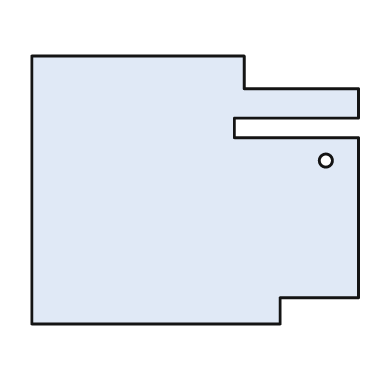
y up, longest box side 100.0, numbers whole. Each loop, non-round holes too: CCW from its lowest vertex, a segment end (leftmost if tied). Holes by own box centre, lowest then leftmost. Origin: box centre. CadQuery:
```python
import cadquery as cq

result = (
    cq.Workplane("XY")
    .moveTo(-50.0, -41.0)
    .lineTo(26.0, -41.0)
    .lineTo(26.0, -33.0)
    .lineTo(50.0, -33.0)
    .lineTo(50.0, 16.0)
    .lineTo(12.0, 16.0)
    .lineTo(12.0, 22.0)
    .lineTo(50.0, 22.0)
    .lineTo(50.0, 31.0)
    .lineTo(15.0, 31.0)
    .lineTo(15.0, 41.0)
    .lineTo(-50.0, 41.0)
    .close()
    .moveTo(40.0, 9.0)
    .circle(2.0)
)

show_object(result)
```